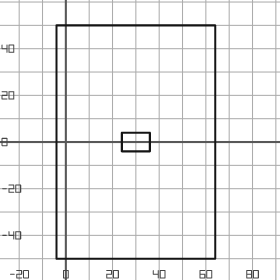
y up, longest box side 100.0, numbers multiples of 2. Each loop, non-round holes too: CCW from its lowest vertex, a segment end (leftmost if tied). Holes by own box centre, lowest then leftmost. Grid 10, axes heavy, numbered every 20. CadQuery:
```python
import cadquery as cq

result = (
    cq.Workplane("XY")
    .moveTo(-4.0, -50.0)
    .lineTo(64.0, -50.0)
    .lineTo(64.0, 50.0)
    .lineTo(-4.0, 50.0)
    .close()
    .moveTo(24.0, -4.0)
    .lineTo(36.0, -4.0)
    .lineTo(36.0, 4.0)
    .lineTo(24.0, 4.0)
    .close()
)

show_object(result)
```